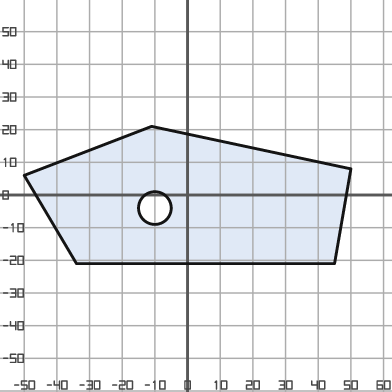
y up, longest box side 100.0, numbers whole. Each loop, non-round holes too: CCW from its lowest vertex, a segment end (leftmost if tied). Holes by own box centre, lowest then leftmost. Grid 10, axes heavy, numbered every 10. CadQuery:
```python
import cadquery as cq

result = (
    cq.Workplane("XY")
    .moveTo(-34.0, -21.0)
    .lineTo(45.0, -21.0)
    .lineTo(50.0, 8.0)
    .lineTo(-11.0, 21.0)
    .lineTo(-50.0, 6.0)
    .close()
    .moveTo(-10.0, -4.0)
    .circle(5.0)
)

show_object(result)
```